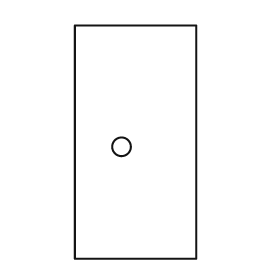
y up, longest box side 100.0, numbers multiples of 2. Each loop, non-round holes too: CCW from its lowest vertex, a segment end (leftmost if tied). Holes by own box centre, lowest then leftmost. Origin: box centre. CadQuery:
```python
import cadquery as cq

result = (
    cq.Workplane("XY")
    .moveTo(-26.0, -50.0)
    .lineTo(26.0, -50.0)
    .lineTo(26.0, 50.0)
    .lineTo(-26.0, 50.0)
    .close()
    .moveTo(-6.0, -2.0)
    .circle(4.0)
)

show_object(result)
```